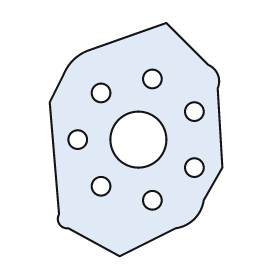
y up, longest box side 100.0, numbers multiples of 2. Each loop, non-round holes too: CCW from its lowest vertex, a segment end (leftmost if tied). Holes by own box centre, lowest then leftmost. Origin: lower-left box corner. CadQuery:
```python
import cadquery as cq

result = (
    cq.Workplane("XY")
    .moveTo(30.0, 0.0)
    .lineTo(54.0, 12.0)
    .threePointArc((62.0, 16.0), (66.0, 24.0))
    .lineTo(74.0, 38.0)
    .lineTo(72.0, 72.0)
    .threePointArc((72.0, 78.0), (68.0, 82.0))
    .lineTo(50.0, 100.0)
    .lineTo(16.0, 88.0)
    .threePointArc((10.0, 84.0), (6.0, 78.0))
    .lineTo(0.0, 66.0)
    .lineTo(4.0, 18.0)
    .threePointArc((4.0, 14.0), (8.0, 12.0))
    .close()
    .moveTo(44.0, 24.0)
    .circle(4.0)
    .moveTo(22.0, 30.0)
    .circle(4.0)
    .moveTo(62.0, 38.0)
    .circle(4.0)
    .moveTo(12.0, 50.0)
    .circle(4.0)
    .moveTo(38.0, 50.0)
    .circle(12.0)
    .moveTo(62.0, 62.0)
    .circle(4.0)
    .moveTo(22.0, 70.0)
    .circle(4.0)
    .moveTo(44.0, 76.0)
    .circle(4.0)
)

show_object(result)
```